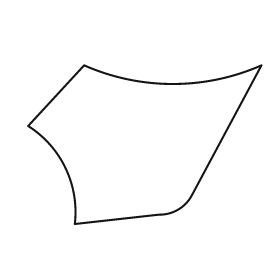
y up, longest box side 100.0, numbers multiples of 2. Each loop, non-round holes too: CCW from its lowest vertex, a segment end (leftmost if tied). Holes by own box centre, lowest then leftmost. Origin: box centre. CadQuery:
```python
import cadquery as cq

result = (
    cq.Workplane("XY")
    .moveTo(-30.0, -34.0)
    .lineTo(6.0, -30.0)
    .threePointArc((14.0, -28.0), (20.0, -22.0))
    .lineTo(50.0, 34.0)
    .threePointArc((12.0, 26.0), (-26.0, 34.0))
    .lineTo(-50.0, 8.0)
    .threePointArc((-34.0, -10.0), (-30.0, -34.0))
    .close()
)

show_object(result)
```